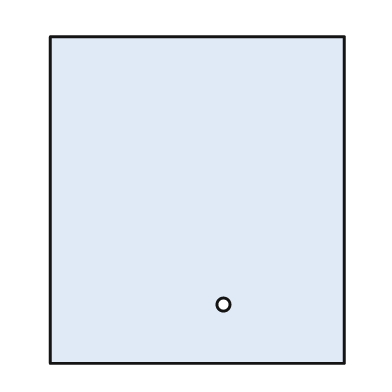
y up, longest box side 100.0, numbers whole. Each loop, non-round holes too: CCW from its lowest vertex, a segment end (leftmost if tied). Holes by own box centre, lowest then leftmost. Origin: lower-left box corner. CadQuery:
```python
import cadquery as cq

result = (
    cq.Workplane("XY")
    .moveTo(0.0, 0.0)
    .lineTo(90.0, 0.0)
    .lineTo(90.0, 100.0)
    .lineTo(0.0, 100.0)
    .close()
    .moveTo(53.0, 18.0)
    .circle(2.0)
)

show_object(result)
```